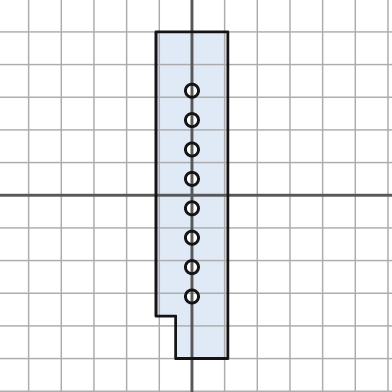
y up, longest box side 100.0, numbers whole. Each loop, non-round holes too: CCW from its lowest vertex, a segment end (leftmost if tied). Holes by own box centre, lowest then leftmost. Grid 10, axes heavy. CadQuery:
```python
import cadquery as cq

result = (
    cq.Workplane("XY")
    .moveTo(-5.0, -50.0)
    .lineTo(11.0, -50.0)
    .lineTo(11.0, 50.0)
    .lineTo(-11.0, 50.0)
    .lineTo(-11.0, -37.0)
    .lineTo(-5.0, -37.0)
    .close()
    .moveTo(0.0, -31.0)
    .circle(2.0)
    .moveTo(0.0, -22.0)
    .circle(2.0)
    .moveTo(0.0, -13.0)
    .circle(2.0)
    .moveTo(0.0, -4.0)
    .circle(2.0)
    .moveTo(0.0, 5.0)
    .circle(2.0)
    .moveTo(0.0, 14.0)
    .circle(2.0)
    .moveTo(0.0, 23.0)
    .circle(2.0)
    .moveTo(0.0, 32.0)
    .circle(2.0)
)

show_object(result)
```